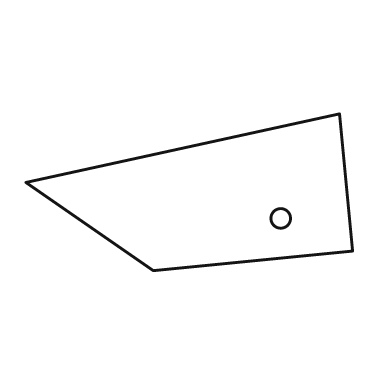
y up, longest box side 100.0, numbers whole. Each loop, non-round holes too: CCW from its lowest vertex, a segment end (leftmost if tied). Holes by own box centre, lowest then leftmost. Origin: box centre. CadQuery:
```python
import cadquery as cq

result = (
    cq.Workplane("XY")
    .moveTo(-11.0, -24.0)
    .lineTo(50.0, -18.0)
    .lineTo(46.0, 24.0)
    .lineTo(-50.0, 3.0)
    .close()
    .moveTo(28.0, -8.0)
    .circle(3.0)
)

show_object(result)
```